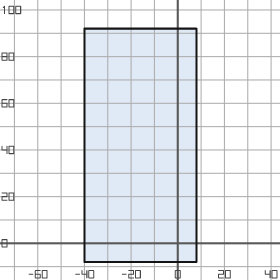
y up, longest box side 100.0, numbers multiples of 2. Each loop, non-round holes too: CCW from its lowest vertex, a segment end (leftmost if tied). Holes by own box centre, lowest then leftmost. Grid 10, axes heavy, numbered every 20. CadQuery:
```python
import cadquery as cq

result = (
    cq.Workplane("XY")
    .moveTo(-40.0, -8.0)
    .lineTo(8.0, -8.0)
    .lineTo(8.0, 92.0)
    .lineTo(-40.0, 92.0)
    .close()
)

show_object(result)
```